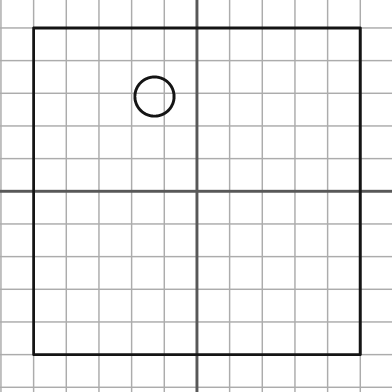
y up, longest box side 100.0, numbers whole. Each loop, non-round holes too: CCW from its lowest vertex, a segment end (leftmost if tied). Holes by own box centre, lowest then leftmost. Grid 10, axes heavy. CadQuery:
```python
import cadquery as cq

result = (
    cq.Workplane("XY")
    .moveTo(-50.0, -50.0)
    .lineTo(50.0, -50.0)
    .lineTo(50.0, 50.0)
    .lineTo(-50.0, 50.0)
    .close()
    .moveTo(-13.0, 29.0)
    .circle(6.0)
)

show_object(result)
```